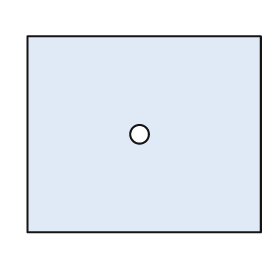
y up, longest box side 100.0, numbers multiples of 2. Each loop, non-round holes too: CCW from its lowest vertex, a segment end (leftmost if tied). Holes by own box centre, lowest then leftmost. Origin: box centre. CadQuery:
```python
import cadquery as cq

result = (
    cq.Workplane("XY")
    .moveTo(-50.0, -42.0)
    .lineTo(50.0, -42.0)
    .lineTo(50.0, 42.0)
    .lineTo(-50.0, 42.0)
    .close()
    .moveTo(-2.0, 0.0)
    .circle(4.0)
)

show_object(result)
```